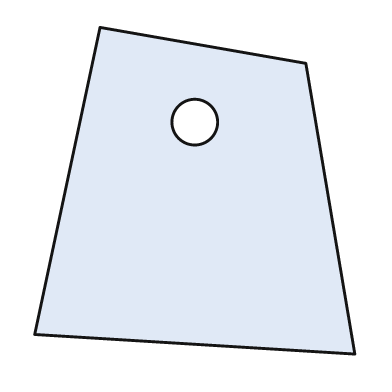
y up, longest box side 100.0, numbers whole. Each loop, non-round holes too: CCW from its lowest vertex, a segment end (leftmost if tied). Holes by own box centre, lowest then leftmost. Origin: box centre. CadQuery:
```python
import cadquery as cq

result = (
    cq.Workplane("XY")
    .moveTo(49.0, -50.0)
    .lineTo(34.0, 39.0)
    .lineTo(-29.0, 50.0)
    .lineTo(-49.0, -44.0)
    .close()
    .moveTo(0.0, 21.0)
    .circle(7.0)
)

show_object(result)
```